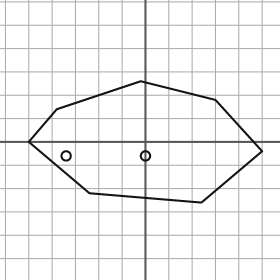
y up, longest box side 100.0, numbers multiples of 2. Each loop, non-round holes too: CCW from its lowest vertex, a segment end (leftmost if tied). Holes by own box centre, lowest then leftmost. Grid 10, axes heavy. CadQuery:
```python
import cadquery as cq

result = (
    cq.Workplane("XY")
    .moveTo(24.0, -26.0)
    .lineTo(50.0, -4.0)
    .lineTo(30.0, 18.0)
    .lineTo(-2.0, 26.0)
    .lineTo(-38.0, 14.0)
    .lineTo(-50.0, 0.0)
    .lineTo(-24.0, -22.0)
    .close()
    .moveTo(-34.0, -6.0)
    .circle(2.0)
    .moveTo(0.0, -6.0)
    .circle(2.0)
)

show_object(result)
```